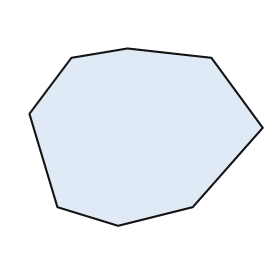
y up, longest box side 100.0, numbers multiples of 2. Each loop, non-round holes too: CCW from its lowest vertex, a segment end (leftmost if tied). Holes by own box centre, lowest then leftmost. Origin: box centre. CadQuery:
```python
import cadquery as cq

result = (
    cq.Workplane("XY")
    .moveTo(-12.0, -38.0)
    .lineTo(20.0, -30.0)
    .lineTo(50.0, 4.0)
    .lineTo(28.0, 34.0)
    .lineTo(-8.0, 38.0)
    .lineTo(-32.0, 34.0)
    .lineTo(-50.0, 10.0)
    .lineTo(-38.0, -30.0)
    .close()
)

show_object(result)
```